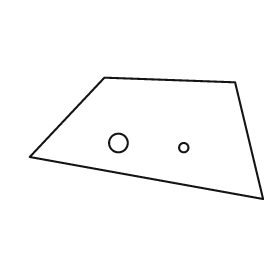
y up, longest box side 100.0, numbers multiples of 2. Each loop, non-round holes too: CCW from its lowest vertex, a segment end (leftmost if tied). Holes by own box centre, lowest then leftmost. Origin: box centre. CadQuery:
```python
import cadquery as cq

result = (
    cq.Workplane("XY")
    .moveTo(50.0, -26.0)
    .lineTo(38.0, 24.0)
    .lineTo(-18.0, 26.0)
    .lineTo(-50.0, -8.0)
    .close()
    .moveTo(16.0, -4.0)
    .circle(2.0)
    .moveTo(-12.0, -2.0)
    .circle(4.0)
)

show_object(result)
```